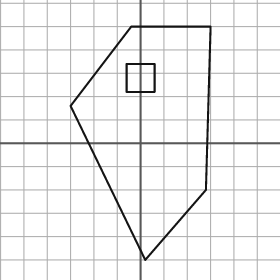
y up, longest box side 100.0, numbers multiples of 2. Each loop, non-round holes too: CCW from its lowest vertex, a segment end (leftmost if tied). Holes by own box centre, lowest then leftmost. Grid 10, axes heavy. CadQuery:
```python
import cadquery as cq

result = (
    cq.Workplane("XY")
    .moveTo(2.0, -50.0)
    .lineTo(28.0, -20.0)
    .lineTo(30.0, 50.0)
    .lineTo(-4.0, 50.0)
    .lineTo(-30.0, 16.0)
    .close()
    .moveTo(-6.0, 22.0)
    .lineTo(6.0, 22.0)
    .lineTo(6.0, 34.0)
    .lineTo(-6.0, 34.0)
    .close()
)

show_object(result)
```